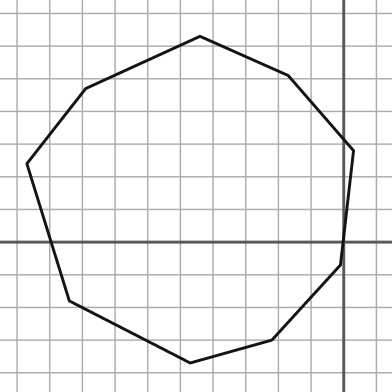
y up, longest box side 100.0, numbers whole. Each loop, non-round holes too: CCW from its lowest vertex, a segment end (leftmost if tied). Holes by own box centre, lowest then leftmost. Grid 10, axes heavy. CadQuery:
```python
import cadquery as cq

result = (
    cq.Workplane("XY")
    .moveTo(-47.0, -37.0)
    .lineTo(-22.0, -30.0)
    .lineTo(-1.0, -7.0)
    .lineTo(3.0, 28.0)
    .lineTo(-17.0, 51.0)
    .lineTo(-44.0, 63.0)
    .lineTo(-79.0, 47.0)
    .lineTo(-97.0, 24.0)
    .lineTo(-84.0, -18.0)
    .close()
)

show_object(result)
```